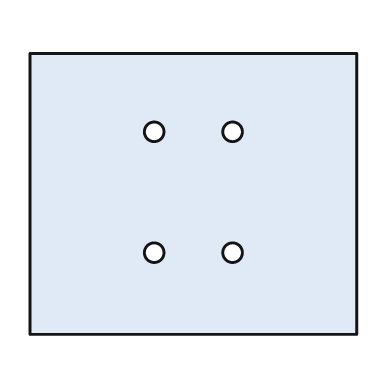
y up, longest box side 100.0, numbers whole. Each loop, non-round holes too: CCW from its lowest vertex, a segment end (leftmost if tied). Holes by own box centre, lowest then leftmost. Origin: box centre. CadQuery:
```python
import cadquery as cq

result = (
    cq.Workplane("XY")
    .moveTo(-50.0, -43.0)
    .lineTo(50.0, -43.0)
    .lineTo(50.0, 43.0)
    .lineTo(-50.0, 43.0)
    .close()
    .moveTo(-12.0, -18.0)
    .circle(3.0)
    .moveTo(12.0, -18.0)
    .circle(3.0)
    .moveTo(-12.0, 19.0)
    .circle(3.0)
    .moveTo(12.0, 19.0)
    .circle(3.0)
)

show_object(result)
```